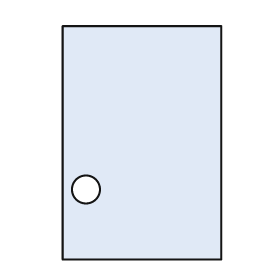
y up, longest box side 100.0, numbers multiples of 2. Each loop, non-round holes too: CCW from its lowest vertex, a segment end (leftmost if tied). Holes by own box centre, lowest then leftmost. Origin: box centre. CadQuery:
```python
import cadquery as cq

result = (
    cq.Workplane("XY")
    .moveTo(-34.0, -50.0)
    .lineTo(34.0, -50.0)
    .lineTo(34.0, 50.0)
    .lineTo(-34.0, 50.0)
    .close()
    .moveTo(-24.0, -20.0)
    .circle(6.0)
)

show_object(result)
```